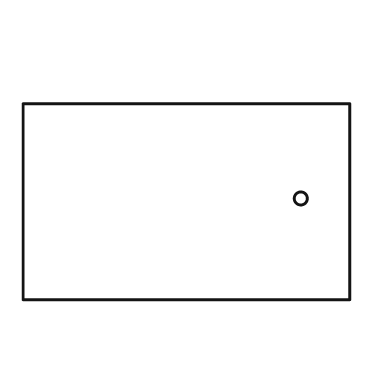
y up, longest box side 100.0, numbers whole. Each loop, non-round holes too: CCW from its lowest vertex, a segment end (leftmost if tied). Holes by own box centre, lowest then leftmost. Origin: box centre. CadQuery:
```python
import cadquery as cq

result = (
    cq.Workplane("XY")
    .moveTo(-50.0, -30.0)
    .lineTo(50.0, -30.0)
    .lineTo(50.0, 30.0)
    .lineTo(-50.0, 30.0)
    .close()
    .moveTo(35.0, 1.0)
    .circle(2.0)
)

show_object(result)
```